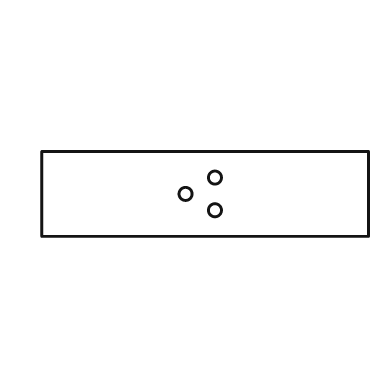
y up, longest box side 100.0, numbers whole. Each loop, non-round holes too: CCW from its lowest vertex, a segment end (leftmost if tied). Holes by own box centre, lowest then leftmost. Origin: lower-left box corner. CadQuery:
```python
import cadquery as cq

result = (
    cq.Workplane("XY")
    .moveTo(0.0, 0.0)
    .lineTo(100.0, 0.0)
    .lineTo(100.0, 26.0)
    .lineTo(0.0, 26.0)
    .close()
    .moveTo(53.0, 8.0)
    .circle(2.0)
    .moveTo(44.0, 13.0)
    .circle(2.0)
    .moveTo(53.0, 18.0)
    .circle(2.0)
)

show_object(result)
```